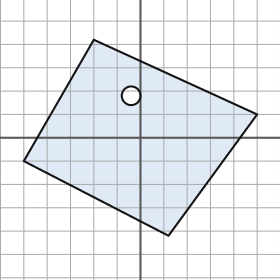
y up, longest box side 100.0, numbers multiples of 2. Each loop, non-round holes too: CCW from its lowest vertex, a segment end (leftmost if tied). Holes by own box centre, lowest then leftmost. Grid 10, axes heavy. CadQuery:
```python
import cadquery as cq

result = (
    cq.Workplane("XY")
    .moveTo(12.0, -42.0)
    .lineTo(50.0, 10.0)
    .lineTo(-20.0, 42.0)
    .lineTo(-50.0, -10.0)
    .close()
    .moveTo(-4.0, 18.0)
    .circle(4.0)
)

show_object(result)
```